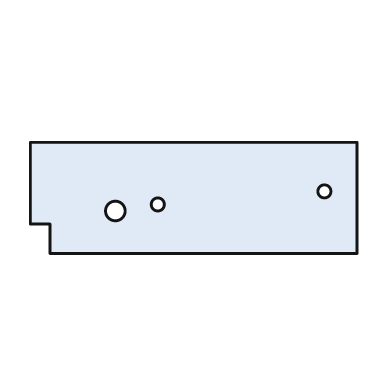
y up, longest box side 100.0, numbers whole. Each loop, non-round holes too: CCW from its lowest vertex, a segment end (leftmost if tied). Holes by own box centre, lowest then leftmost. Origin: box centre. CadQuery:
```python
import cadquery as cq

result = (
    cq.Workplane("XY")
    .moveTo(-44.0, -17.0)
    .lineTo(50.0, -17.0)
    .lineTo(50.0, 17.0)
    .lineTo(-50.0, 17.0)
    .lineTo(-50.0, -8.0)
    .lineTo(-44.0, -8.0)
    .close()
    .moveTo(-24.0, -4.0)
    .circle(3.0)
    .moveTo(-11.0, -2.0)
    .circle(2.0)
    .moveTo(40.0, 2.0)
    .circle(2.0)
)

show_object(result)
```